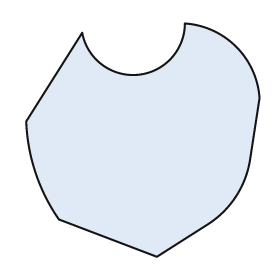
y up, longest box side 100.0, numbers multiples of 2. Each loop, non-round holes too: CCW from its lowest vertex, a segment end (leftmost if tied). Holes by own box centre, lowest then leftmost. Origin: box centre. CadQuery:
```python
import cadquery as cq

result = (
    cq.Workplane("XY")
    .moveTo(6.0, -50.0)
    .lineTo(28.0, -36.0)
    .threePointArc((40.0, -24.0), (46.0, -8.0))
    .lineTo(50.0, 18.0)
    .threePointArc((40.0, 40.0), (18.0, 50.0))
    .threePointArc((-2.0, 28.0), (-26.0, 46.0))
    .lineTo(-50.0, 8.0)
    .threePointArc((-46.0, -14.0), (-36.0, -34.0))
    .close()
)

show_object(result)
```